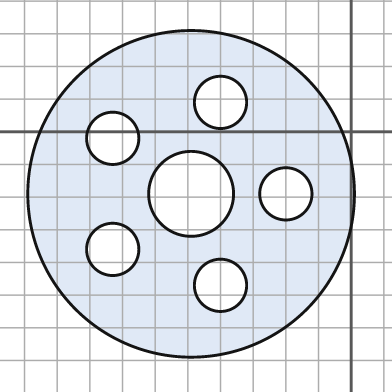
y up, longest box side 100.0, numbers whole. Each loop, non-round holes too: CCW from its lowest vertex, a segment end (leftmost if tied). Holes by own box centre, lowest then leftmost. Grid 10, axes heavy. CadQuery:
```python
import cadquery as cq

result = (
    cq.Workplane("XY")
    .moveTo(-49.0, -19.0)
    .circle(50.0)
    .moveTo(-40.0, -47.0)
    .circle(8.0)
    .moveTo(-73.0, -36.0)
    .circle(8.0)
    .moveTo(-49.0, -19.0)
    .circle(13.0)
    .moveTo(-20.0, -19.0)
    .circle(8.0)
    .moveTo(-73.0, -2.0)
    .circle(8.0)
    .moveTo(-40.0, 9.0)
    .circle(8.0)
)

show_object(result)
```